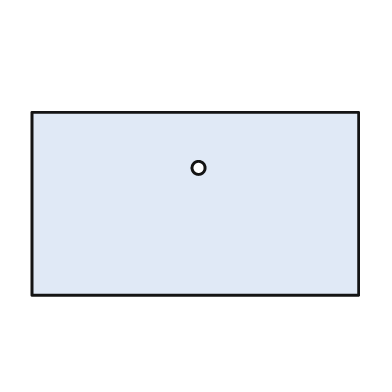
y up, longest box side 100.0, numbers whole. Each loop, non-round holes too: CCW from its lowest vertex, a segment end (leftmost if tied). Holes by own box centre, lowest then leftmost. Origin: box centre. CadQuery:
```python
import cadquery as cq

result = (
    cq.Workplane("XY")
    .moveTo(-50.0, -28.0)
    .lineTo(50.0, -28.0)
    .lineTo(50.0, 28.0)
    .lineTo(-50.0, 28.0)
    .close()
    .moveTo(1.0, 11.0)
    .circle(2.0)
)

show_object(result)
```